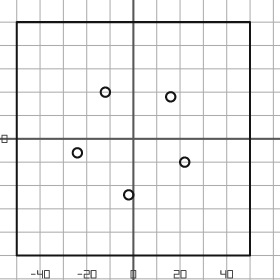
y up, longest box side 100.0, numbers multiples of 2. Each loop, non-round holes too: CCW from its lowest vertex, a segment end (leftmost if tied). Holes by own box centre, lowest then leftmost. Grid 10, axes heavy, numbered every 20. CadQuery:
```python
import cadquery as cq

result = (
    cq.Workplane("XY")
    .moveTo(-50.0, -50.0)
    .lineTo(50.0, -50.0)
    .lineTo(50.0, 50.0)
    .lineTo(-50.0, 50.0)
    .close()
    .moveTo(-2.0, -24.0)
    .circle(2.0)
    .moveTo(22.0, -10.0)
    .circle(2.0)
    .moveTo(-24.0, -6.0)
    .circle(2.0)
    .moveTo(16.0, 18.0)
    .circle(2.0)
    .moveTo(-12.0, 20.0)
    .circle(2.0)
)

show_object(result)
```